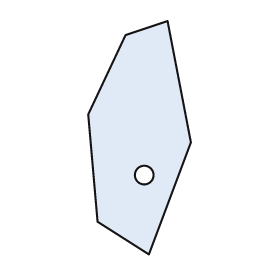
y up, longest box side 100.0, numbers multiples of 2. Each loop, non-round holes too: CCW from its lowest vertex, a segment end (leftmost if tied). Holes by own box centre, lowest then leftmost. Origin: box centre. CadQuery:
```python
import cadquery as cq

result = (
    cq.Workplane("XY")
    .moveTo(4.0, -50.0)
    .lineTo(22.0, -2.0)
    .lineTo(12.0, 50.0)
    .lineTo(-6.0, 44.0)
    .lineTo(-22.0, 10.0)
    .lineTo(-18.0, -36.0)
    .close()
    .moveTo(2.0, -16.0)
    .circle(4.0)
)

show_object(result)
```